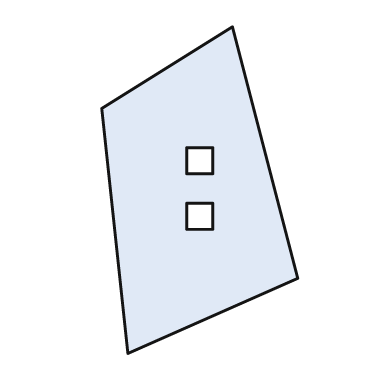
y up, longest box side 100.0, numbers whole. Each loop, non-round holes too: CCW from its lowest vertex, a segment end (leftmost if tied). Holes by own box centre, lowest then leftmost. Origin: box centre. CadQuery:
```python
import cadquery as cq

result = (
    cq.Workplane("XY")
    .moveTo(-22.0, -50.0)
    .lineTo(30.0, -27.0)
    .lineTo(10.0, 50.0)
    .lineTo(-30.0, 25.0)
    .close()
    .moveTo(-4.0, -12.0)
    .lineTo(4.0, -12.0)
    .lineTo(4.0, -4.0)
    .lineTo(-4.0, -4.0)
    .close()
    .moveTo(-4.0, 5.0)
    .lineTo(4.0, 5.0)
    .lineTo(4.0, 13.0)
    .lineTo(-4.0, 13.0)
    .close()
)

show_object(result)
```